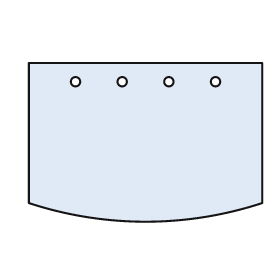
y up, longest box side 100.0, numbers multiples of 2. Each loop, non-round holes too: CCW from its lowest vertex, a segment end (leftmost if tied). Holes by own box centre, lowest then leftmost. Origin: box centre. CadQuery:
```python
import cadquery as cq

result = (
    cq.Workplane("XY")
    .moveTo(-50.0, -26.0)
    .threePointArc((0.0, -34.0), (50.0, -26.0))
    .lineTo(50.0, 34.0)
    .lineTo(-50.0, 34.0)
    .close()
    .moveTo(-30.0, 26.0)
    .circle(2.0)
    .moveTo(-10.0, 26.0)
    .circle(2.0)
    .moveTo(10.0, 26.0)
    .circle(2.0)
    .moveTo(30.0, 26.0)
    .circle(2.0)
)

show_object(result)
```